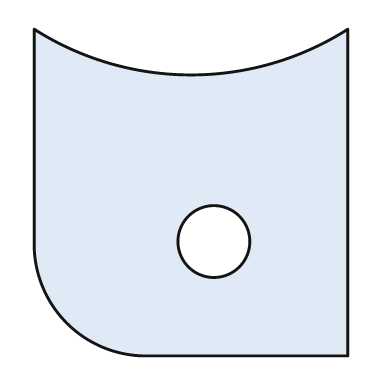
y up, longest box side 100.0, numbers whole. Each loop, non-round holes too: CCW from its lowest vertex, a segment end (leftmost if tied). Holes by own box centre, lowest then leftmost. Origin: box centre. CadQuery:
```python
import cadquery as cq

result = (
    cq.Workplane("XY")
    .moveTo(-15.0, -50.0)
    .lineTo(48.0, -50.0)
    .lineTo(48.0, 50.0)
    .threePointArc((0.0, 36.0), (-48.0, 50.0))
    .lineTo(-48.0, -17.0)
    .threePointArc((-38.0, -40.0), (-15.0, -50.0))
    .close()
    .moveTo(7.0, -15.0)
    .circle(11.0)
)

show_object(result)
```